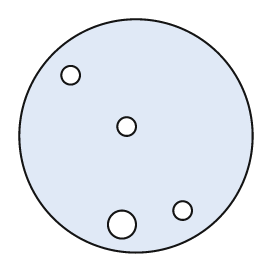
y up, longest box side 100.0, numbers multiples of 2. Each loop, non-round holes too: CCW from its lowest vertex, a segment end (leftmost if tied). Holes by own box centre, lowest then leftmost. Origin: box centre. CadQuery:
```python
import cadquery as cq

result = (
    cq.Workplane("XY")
    .moveTo(0.0, 0.0)
    .circle(50.0)
    .moveTo(-6.0, -38.0)
    .circle(6.0)
    .moveTo(20.0, -32.0)
    .circle(4.0)
    .moveTo(-4.0, 4.0)
    .circle(4.0)
    .moveTo(-28.0, 26.0)
    .circle(4.0)
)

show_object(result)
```